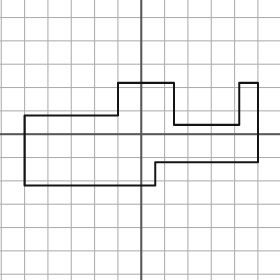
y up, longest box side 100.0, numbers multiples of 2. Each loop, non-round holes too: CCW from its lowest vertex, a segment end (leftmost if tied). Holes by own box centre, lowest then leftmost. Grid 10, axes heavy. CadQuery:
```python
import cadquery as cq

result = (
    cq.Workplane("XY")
    .moveTo(-50.0, -22.0)
    .lineTo(6.0, -22.0)
    .lineTo(6.0, -12.0)
    .lineTo(50.0, -12.0)
    .lineTo(50.0, 22.0)
    .lineTo(42.0, 22.0)
    .lineTo(42.0, 4.0)
    .lineTo(14.0, 4.0)
    .lineTo(14.0, 22.0)
    .lineTo(-10.0, 22.0)
    .lineTo(-10.0, 8.0)
    .lineTo(-50.0, 8.0)
    .close()
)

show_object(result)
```